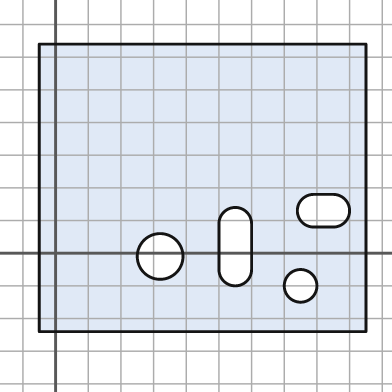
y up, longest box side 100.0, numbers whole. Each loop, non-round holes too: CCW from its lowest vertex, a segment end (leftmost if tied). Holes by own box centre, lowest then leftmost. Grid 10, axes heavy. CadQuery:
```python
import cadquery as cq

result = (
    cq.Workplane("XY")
    .moveTo(-5.0, -24.0)
    .lineTo(95.0, -24.0)
    .lineTo(95.0, 64.0)
    .lineTo(-5.0, 64.0)
    .close()
    .moveTo(75.0, -10.0)
    .circle(5.0)
    .moveTo(32.0, -1.0)
    .circle(7.0)
    .moveTo(50.0, -5.0)
    .threePointArc((55.0, -10.0), (60.0, -5.0))
    .lineTo(60.0, 9.0)
    .threePointArc((55.0, 14.0), (50.0, 9.0))
    .close()
    .moveTo(79.0, 8.0)
    .lineTo(85.0, 8.0)
    .threePointArc((90.0, 13.0), (85.0, 18.0))
    .lineTo(79.0, 18.0)
    .threePointArc((74.0, 13.0), (79.0, 8.0))
    .close()
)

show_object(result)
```